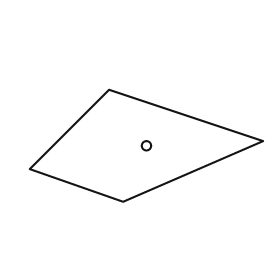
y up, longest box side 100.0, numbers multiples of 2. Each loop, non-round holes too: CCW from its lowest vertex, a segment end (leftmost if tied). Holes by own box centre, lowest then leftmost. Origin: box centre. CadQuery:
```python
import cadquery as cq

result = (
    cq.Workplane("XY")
    .moveTo(-10.0, -24.0)
    .lineTo(50.0, 2.0)
    .lineTo(-16.0, 24.0)
    .lineTo(-50.0, -10.0)
    .close()
    .moveTo(0.0, 0.0)
    .circle(2.0)
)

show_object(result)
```